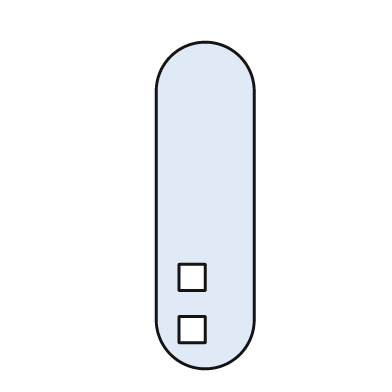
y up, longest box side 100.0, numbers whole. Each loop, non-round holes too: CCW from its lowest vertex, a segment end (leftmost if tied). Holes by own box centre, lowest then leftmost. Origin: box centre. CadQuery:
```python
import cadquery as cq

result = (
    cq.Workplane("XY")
    .moveTo(-15.0, -35.0)
    .threePointArc((0.0, -50.0), (15.0, -35.0))
    .lineTo(15.0, 35.0)
    .threePointArc((0.0, 50.0), (-15.0, 35.0))
    .close()
    .moveTo(-8.0, -42.0)
    .lineTo(0.0, -42.0)
    .lineTo(0.0, -34.0)
    .lineTo(-8.0, -34.0)
    .close()
    .moveTo(-8.0, -26.0)
    .lineTo(0.0, -26.0)
    .lineTo(0.0, -18.0)
    .lineTo(-8.0, -18.0)
    .close()
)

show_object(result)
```